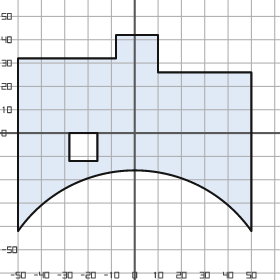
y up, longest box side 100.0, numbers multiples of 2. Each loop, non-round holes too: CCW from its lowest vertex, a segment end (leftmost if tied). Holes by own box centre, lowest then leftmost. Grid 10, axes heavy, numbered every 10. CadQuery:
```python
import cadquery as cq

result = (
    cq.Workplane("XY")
    .moveTo(-50.0, -42.0)
    .threePointArc((0.0, -16.0), (50.0, -42.0))
    .lineTo(50.0, 26.0)
    .lineTo(10.0, 26.0)
    .lineTo(10.0, 42.0)
    .lineTo(-8.0, 42.0)
    .lineTo(-8.0, 32.0)
    .lineTo(-50.0, 32.0)
    .close()
    .moveTo(-28.0, -12.0)
    .lineTo(-16.0, -12.0)
    .lineTo(-16.0, 0.0)
    .lineTo(-28.0, 0.0)
    .close()
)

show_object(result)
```